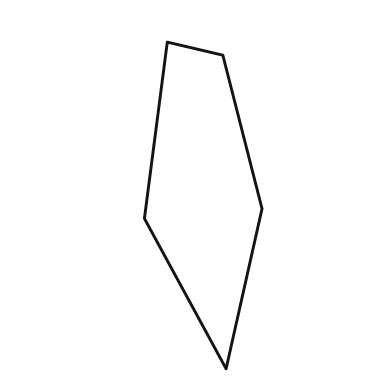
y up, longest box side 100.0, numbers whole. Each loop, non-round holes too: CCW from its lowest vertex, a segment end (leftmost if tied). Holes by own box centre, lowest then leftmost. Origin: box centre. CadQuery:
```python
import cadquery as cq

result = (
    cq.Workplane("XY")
    .moveTo(7.0, -50.0)
    .lineTo(18.0, -1.0)
    .lineTo(6.0, 46.0)
    .lineTo(-11.0, 50.0)
    .lineTo(-18.0, -4.0)
    .close()
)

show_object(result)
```